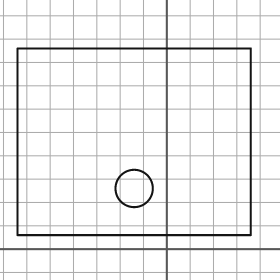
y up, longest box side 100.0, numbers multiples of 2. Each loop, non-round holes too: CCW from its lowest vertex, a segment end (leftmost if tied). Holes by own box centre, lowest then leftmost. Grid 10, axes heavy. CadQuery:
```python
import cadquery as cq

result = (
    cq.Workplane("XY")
    .moveTo(-64.0, 6.0)
    .lineTo(36.0, 6.0)
    .lineTo(36.0, 86.0)
    .lineTo(-64.0, 86.0)
    .close()
    .moveTo(-14.0, 26.0)
    .circle(8.0)
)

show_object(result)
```